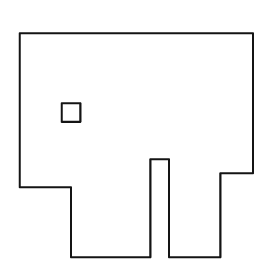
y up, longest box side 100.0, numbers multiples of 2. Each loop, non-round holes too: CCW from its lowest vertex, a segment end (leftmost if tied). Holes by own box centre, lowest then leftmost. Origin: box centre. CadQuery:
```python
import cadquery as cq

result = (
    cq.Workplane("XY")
    .moveTo(-28.0, -48.0)
    .lineTo(6.0, -48.0)
    .lineTo(6.0, -6.0)
    .lineTo(14.0, -6.0)
    .lineTo(14.0, -48.0)
    .lineTo(36.0, -48.0)
    .lineTo(36.0, -12.0)
    .lineTo(50.0, -12.0)
    .lineTo(50.0, 48.0)
    .lineTo(-50.0, 48.0)
    .lineTo(-50.0, -18.0)
    .lineTo(-28.0, -18.0)
    .close()
    .moveTo(-32.0, 10.0)
    .lineTo(-24.0, 10.0)
    .lineTo(-24.0, 18.0)
    .lineTo(-32.0, 18.0)
    .close()
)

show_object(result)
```